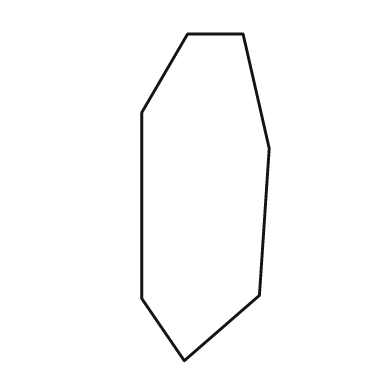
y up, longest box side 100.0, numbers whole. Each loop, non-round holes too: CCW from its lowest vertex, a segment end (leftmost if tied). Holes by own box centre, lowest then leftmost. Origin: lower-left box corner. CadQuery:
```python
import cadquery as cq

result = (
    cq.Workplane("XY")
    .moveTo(13.0, 0.0)
    .lineTo(36.0, 20.0)
    .lineTo(39.0, 65.0)
    .lineTo(31.0, 100.0)
    .lineTo(14.0, 100.0)
    .lineTo(0.0, 76.0)
    .lineTo(0.0, 19.0)
    .close()
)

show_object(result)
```